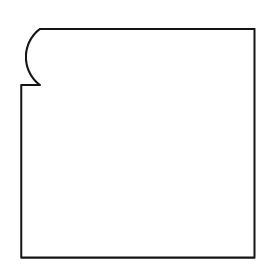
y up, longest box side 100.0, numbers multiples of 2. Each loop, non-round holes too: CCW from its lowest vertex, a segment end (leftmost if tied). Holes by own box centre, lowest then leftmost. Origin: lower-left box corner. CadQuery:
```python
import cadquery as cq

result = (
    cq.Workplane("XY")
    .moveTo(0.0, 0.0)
    .lineTo(100.0, 0.0)
    .lineTo(100.0, 98.0)
    .lineTo(8.0, 98.0)
    .threePointArc((2.0, 86.0), (8.0, 74.0))
    .lineTo(0.0, 74.0)
    .close()
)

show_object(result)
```